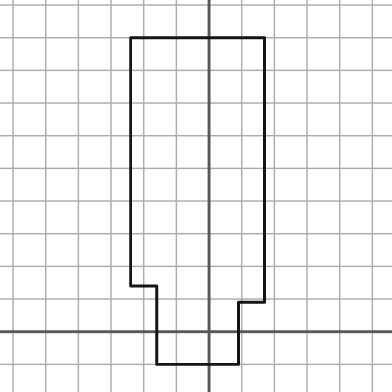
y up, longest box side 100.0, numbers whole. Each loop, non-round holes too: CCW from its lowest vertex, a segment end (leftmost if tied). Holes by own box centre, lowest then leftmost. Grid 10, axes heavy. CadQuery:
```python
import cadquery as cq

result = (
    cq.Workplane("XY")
    .moveTo(-16.0, -10.0)
    .lineTo(9.0, -10.0)
    .lineTo(9.0, 9.0)
    .lineTo(17.0, 9.0)
    .lineTo(17.0, 90.0)
    .lineTo(-24.0, 90.0)
    .lineTo(-24.0, 14.0)
    .lineTo(-16.0, 14.0)
    .close()
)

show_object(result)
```